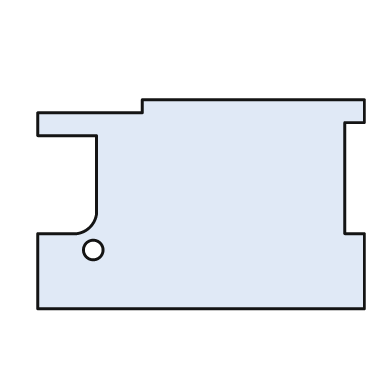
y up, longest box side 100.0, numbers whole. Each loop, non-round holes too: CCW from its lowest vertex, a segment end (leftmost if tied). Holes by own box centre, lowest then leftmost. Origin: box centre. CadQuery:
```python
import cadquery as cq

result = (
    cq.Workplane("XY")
    .moveTo(-50.0, -32.0)
    .lineTo(50.0, -32.0)
    .lineTo(50.0, -9.0)
    .lineTo(44.0, -9.0)
    .lineTo(44.0, 25.0)
    .lineTo(50.0, 25.0)
    .lineTo(50.0, 32.0)
    .lineTo(-18.0, 32.0)
    .lineTo(-18.0, 28.0)
    .lineTo(-50.0, 28.0)
    .lineTo(-50.0, 21.0)
    .lineTo(-32.0, 21.0)
    .lineTo(-32.0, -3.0)
    .threePointArc((-34.0, -7.0), (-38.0, -9.0))
    .lineTo(-50.0, -9.0)
    .close()
    .moveTo(-33.0, -14.0)
    .circle(3.0)
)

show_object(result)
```